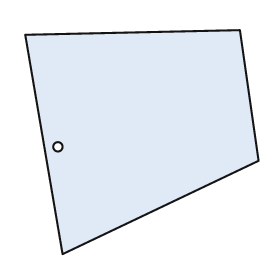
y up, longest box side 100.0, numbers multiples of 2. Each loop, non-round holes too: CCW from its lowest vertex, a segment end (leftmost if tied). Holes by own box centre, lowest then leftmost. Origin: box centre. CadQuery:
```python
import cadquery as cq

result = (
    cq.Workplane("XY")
    .moveTo(-34.0, -48.0)
    .lineTo(50.0, -8.0)
    .lineTo(42.0, 48.0)
    .lineTo(-50.0, 46.0)
    .close()
    .moveTo(-36.0, -2.0)
    .circle(2.0)
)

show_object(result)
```